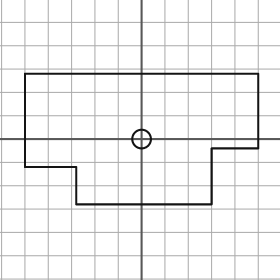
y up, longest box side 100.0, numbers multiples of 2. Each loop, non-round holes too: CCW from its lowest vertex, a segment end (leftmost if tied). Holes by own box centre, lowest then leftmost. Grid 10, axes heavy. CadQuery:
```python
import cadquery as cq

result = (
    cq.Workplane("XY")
    .moveTo(-28.0, -28.0)
    .lineTo(30.0, -28.0)
    .lineTo(30.0, -4.0)
    .lineTo(50.0, -4.0)
    .lineTo(50.0, 28.0)
    .lineTo(-50.0, 28.0)
    .lineTo(-50.0, -12.0)
    .lineTo(-28.0, -12.0)
    .close()
    .moveTo(0.0, 0.0)
    .circle(4.0)
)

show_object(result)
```